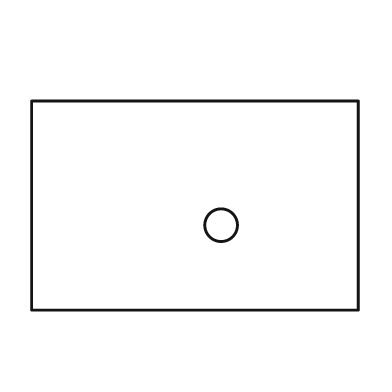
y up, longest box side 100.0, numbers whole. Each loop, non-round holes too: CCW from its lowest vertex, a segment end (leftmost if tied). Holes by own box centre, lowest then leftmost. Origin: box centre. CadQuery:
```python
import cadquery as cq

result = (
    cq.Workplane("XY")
    .moveTo(-50.0, -32.0)
    .lineTo(50.0, -32.0)
    .lineTo(50.0, 32.0)
    .lineTo(-50.0, 32.0)
    .close()
    .moveTo(8.0, -6.0)
    .circle(5.0)
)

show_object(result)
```